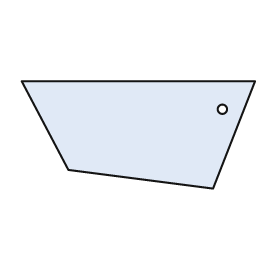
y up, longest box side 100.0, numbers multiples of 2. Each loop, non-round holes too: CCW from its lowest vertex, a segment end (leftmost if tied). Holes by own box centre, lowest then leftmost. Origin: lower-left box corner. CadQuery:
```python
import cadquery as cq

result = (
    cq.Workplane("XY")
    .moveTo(82.0, 0.0)
    .lineTo(100.0, 46.0)
    .lineTo(0.0, 46.0)
    .lineTo(20.0, 8.0)
    .close()
    .moveTo(86.0, 34.0)
    .circle(2.0)
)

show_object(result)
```